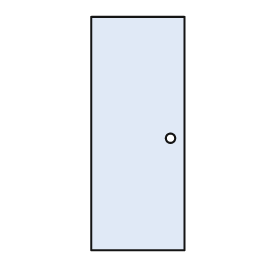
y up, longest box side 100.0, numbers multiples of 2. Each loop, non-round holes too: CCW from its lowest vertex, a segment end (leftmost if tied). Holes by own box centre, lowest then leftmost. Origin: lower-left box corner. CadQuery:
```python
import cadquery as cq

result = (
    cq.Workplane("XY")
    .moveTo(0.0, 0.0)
    .lineTo(40.0, 0.0)
    .lineTo(40.0, 100.0)
    .lineTo(0.0, 100.0)
    .close()
    .moveTo(34.0, 48.0)
    .circle(2.0)
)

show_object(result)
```